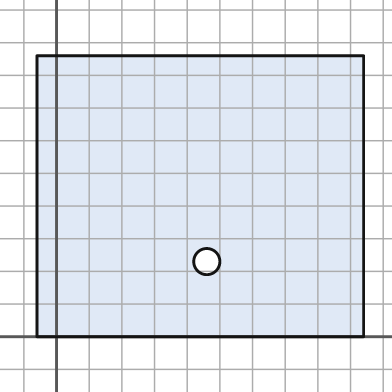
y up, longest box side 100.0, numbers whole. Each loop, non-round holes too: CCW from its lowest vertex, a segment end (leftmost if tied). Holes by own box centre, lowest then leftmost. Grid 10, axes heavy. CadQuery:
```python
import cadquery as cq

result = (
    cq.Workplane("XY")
    .moveTo(-6.0, 0.0)
    .lineTo(94.0, 0.0)
    .lineTo(94.0, 86.0)
    .lineTo(-6.0, 86.0)
    .close()
    .moveTo(46.0, 23.0)
    .circle(4.0)
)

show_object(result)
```